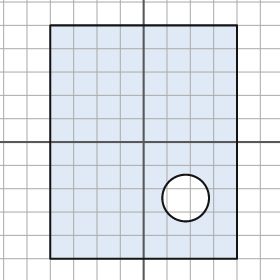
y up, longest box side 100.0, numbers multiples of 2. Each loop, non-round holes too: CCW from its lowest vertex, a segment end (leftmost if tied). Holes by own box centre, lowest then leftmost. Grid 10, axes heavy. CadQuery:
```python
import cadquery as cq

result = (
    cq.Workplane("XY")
    .moveTo(-40.0, -50.0)
    .lineTo(40.0, -50.0)
    .lineTo(40.0, 50.0)
    .lineTo(-40.0, 50.0)
    .close()
    .moveTo(18.0, -24.0)
    .circle(10.0)
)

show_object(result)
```